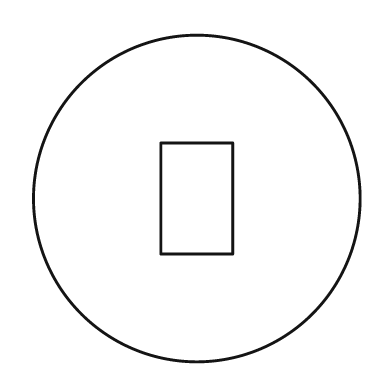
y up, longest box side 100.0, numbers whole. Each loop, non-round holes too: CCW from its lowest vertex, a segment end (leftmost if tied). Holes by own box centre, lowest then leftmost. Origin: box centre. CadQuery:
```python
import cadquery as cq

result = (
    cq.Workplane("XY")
    .moveTo(0.0, 0.0)
    .circle(50.0)
    .moveTo(-11.0, -17.0)
    .lineTo(11.0, -17.0)
    .lineTo(11.0, 17.0)
    .lineTo(-11.0, 17.0)
    .close()
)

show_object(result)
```